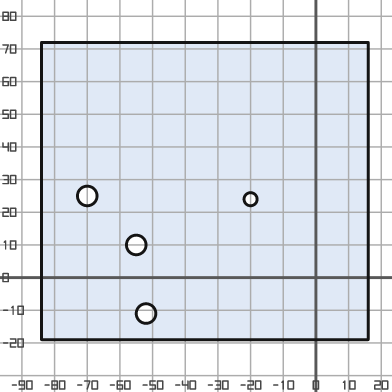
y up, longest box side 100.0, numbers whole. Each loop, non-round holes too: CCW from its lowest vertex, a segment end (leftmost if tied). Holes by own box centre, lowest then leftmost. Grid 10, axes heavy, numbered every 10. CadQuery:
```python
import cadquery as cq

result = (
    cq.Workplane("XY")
    .moveTo(-84.0, -19.0)
    .lineTo(16.0, -19.0)
    .lineTo(16.0, 72.0)
    .lineTo(-84.0, 72.0)
    .close()
    .moveTo(-52.0, -11.0)
    .circle(3.0)
    .moveTo(-55.0, 10.0)
    .circle(3.0)
    .moveTo(-20.0, 24.0)
    .circle(2.0)
    .moveTo(-70.0, 25.0)
    .circle(3.0)
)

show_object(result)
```